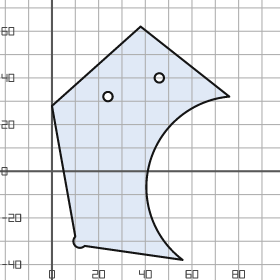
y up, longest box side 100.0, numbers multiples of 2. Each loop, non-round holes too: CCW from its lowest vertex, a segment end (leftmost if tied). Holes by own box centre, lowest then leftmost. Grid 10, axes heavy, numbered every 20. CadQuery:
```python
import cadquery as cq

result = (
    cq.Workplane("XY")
    .moveTo(56.0, -38.0)
    .threePointArc((42.0, 4.0), (76.0, 32.0))
    .lineTo(38.0, 62.0)
    .lineTo(0.0, 28.0)
    .lineTo(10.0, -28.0)
    .threePointArc((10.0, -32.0), (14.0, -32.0))
    .close()
    .moveTo(24.0, 32.0)
    .circle(2.0)
    .moveTo(46.0, 40.0)
    .circle(2.0)
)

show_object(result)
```